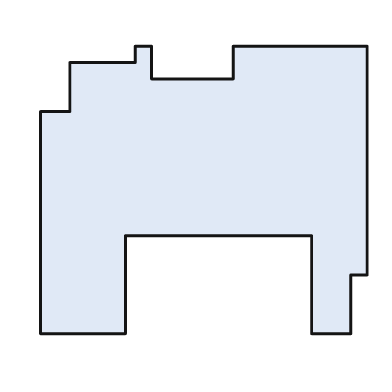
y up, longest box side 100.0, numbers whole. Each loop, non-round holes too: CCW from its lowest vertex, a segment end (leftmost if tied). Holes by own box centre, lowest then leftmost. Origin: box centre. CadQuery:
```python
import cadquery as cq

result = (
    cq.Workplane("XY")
    .moveTo(-50.0, -44.0)
    .lineTo(-24.0, -44.0)
    .lineTo(-24.0, -14.0)
    .lineTo(33.0, -14.0)
    .lineTo(33.0, -44.0)
    .lineTo(45.0, -44.0)
    .lineTo(45.0, -26.0)
    .lineTo(50.0, -26.0)
    .lineTo(50.0, 44.0)
    .lineTo(9.0, 44.0)
    .lineTo(9.0, 34.0)
    .lineTo(-16.0, 34.0)
    .lineTo(-16.0, 44.0)
    .lineTo(-21.0, 44.0)
    .lineTo(-21.0, 39.0)
    .lineTo(-41.0, 39.0)
    .lineTo(-41.0, 24.0)
    .lineTo(-50.0, 24.0)
    .close()
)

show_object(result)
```